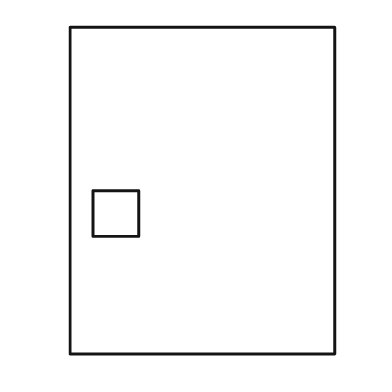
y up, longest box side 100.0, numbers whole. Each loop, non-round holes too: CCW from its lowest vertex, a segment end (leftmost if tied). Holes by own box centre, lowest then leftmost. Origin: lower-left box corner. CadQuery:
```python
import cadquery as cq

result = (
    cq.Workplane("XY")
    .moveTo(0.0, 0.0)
    .lineTo(81.0, 0.0)
    .lineTo(81.0, 100.0)
    .lineTo(0.0, 100.0)
    .close()
    .moveTo(7.0, 36.0)
    .lineTo(21.0, 36.0)
    .lineTo(21.0, 50.0)
    .lineTo(7.0, 50.0)
    .close()
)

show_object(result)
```